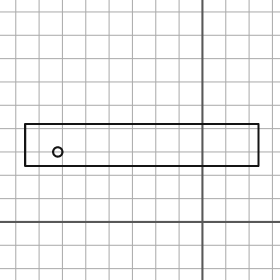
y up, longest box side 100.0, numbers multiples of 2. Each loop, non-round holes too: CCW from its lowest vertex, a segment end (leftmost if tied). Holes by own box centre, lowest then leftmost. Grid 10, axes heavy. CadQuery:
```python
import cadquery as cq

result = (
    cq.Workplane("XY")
    .moveTo(-76.0, 24.0)
    .lineTo(24.0, 24.0)
    .lineTo(24.0, 42.0)
    .lineTo(-76.0, 42.0)
    .close()
    .moveTo(-62.0, 30.0)
    .circle(2.0)
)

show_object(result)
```